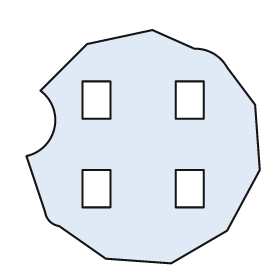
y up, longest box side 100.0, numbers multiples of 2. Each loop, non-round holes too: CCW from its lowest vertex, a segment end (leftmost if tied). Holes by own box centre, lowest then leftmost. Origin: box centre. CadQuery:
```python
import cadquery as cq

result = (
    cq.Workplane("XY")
    .moveTo(12.0, -50.0)
    .lineTo(36.0, -36.0)
    .lineTo(50.0, -10.0)
    .lineTo(48.0, 18.0)
    .lineTo(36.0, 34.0)
    .threePointArc((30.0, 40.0), (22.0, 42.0))
    .lineTo(4.0, 50.0)
    .lineTo(-24.0, 44.0)
    .lineTo(-44.0, 24.0)
    .threePointArc((-38.0, 8.0), (-50.0, -4.0))
    .lineTo(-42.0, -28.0)
    .threePointArc((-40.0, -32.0), (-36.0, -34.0))
    .lineTo(-16.0, -48.0)
    .close()
    .moveTo(-26.0, -26.0)
    .lineTo(-14.0, -26.0)
    .lineTo(-14.0, -10.0)
    .lineTo(-26.0, -10.0)
    .close()
    .moveTo(14.0, -26.0)
    .lineTo(26.0, -26.0)
    .lineTo(26.0, -10.0)
    .lineTo(14.0, -10.0)
    .close()
    .moveTo(-26.0, 12.0)
    .lineTo(-14.0, 12.0)
    .lineTo(-14.0, 28.0)
    .lineTo(-26.0, 28.0)
    .close()
    .moveTo(14.0, 12.0)
    .lineTo(26.0, 12.0)
    .lineTo(26.0, 28.0)
    .lineTo(14.0, 28.0)
    .close()
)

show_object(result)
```